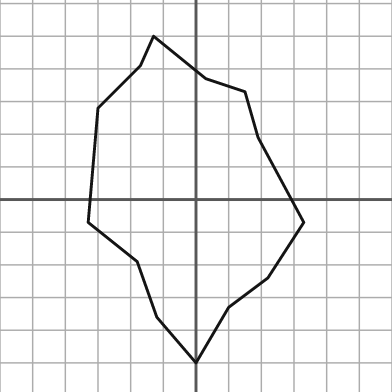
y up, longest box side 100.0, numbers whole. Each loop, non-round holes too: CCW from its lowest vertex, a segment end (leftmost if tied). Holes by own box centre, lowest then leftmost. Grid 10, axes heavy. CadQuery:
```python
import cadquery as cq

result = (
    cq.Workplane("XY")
    .moveTo(0.0, -50.0)
    .lineTo(10.0, -33.0)
    .lineTo(22.0, -24.0)
    .lineTo(33.0, -7.0)
    .lineTo(19.0, 19.0)
    .lineTo(15.0, 33.0)
    .lineTo(3.0, 37.0)
    .lineTo(-13.0, 50.0)
    .lineTo(-17.0, 41.0)
    .lineTo(-30.0, 28.0)
    .lineTo(-33.0, -7.0)
    .lineTo(-18.0, -19.0)
    .lineTo(-12.0, -36.0)
    .close()
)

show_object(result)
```